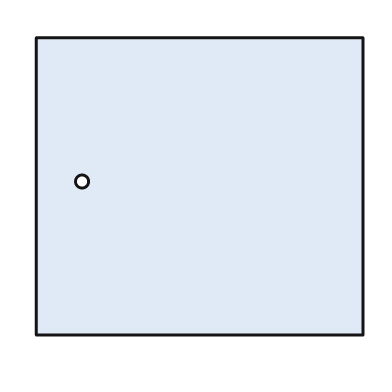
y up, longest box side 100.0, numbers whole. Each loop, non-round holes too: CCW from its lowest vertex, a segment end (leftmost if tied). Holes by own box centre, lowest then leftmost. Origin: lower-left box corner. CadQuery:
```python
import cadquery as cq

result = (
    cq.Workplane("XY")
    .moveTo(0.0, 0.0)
    .lineTo(100.0, 0.0)
    .lineTo(100.0, 91.0)
    .lineTo(0.0, 91.0)
    .close()
    .moveTo(14.0, 47.0)
    .circle(2.0)
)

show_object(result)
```